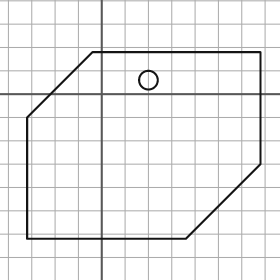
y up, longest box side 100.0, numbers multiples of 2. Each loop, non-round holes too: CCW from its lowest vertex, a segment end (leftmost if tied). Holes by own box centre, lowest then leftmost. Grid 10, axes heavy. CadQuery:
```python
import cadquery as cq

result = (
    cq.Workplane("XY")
    .moveTo(-32.0, -62.0)
    .lineTo(36.0, -62.0)
    .lineTo(68.0, -30.0)
    .lineTo(68.0, 18.0)
    .lineTo(-4.0, 18.0)
    .lineTo(-32.0, -10.0)
    .close()
    .moveTo(20.0, 6.0)
    .circle(4.0)
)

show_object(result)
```